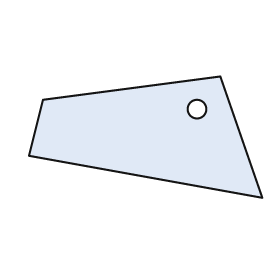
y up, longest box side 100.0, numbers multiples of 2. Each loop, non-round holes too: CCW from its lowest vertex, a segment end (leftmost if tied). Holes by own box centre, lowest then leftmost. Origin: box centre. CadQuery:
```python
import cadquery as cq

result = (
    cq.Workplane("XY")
    .moveTo(50.0, -26.0)
    .lineTo(32.0, 26.0)
    .lineTo(-44.0, 16.0)
    .lineTo(-50.0, -8.0)
    .close()
    .moveTo(22.0, 12.0)
    .circle(4.0)
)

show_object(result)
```